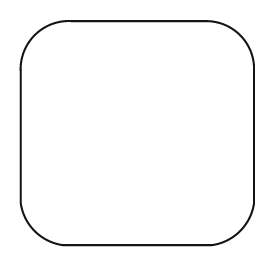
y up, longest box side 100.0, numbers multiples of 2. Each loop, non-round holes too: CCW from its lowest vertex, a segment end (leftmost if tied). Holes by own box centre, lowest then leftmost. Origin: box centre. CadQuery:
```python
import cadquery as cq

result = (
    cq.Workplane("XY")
    .moveTo(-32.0, -48.0)
    .lineTo(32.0, -48.0)
    .threePointArc((44.0, -42.0), (50.0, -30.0))
    .lineTo(50.0, 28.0)
    .threePointArc((44.0, 42.0), (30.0, 48.0))
    .lineTo(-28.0, 48.0)
    .threePointArc((-44.0, 42.0), (-50.0, 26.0))
    .lineTo(-50.0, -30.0)
    .threePointArc((-44.0, -42.0), (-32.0, -48.0))
    .close()
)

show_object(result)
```